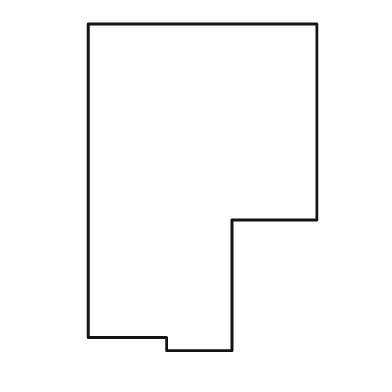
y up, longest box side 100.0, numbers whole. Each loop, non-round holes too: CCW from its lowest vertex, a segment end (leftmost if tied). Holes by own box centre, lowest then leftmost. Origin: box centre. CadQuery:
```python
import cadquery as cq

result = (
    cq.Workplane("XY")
    .moveTo(-11.0, -50.0)
    .lineTo(9.0, -50.0)
    .lineTo(9.0, -10.0)
    .lineTo(35.0, -10.0)
    .lineTo(35.0, 50.0)
    .lineTo(-35.0, 50.0)
    .lineTo(-35.0, -46.0)
    .lineTo(-11.0, -46.0)
    .close()
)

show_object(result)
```